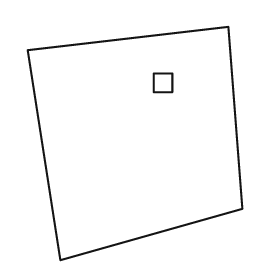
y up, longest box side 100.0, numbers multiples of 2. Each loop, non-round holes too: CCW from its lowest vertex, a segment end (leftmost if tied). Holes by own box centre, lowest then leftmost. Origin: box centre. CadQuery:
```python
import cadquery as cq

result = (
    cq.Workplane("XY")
    .moveTo(-32.0, -50.0)
    .lineTo(46.0, -28.0)
    .lineTo(40.0, 50.0)
    .lineTo(-46.0, 40.0)
    .close()
    .moveTo(8.0, 22.0)
    .lineTo(16.0, 22.0)
    .lineTo(16.0, 30.0)
    .lineTo(8.0, 30.0)
    .close()
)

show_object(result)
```